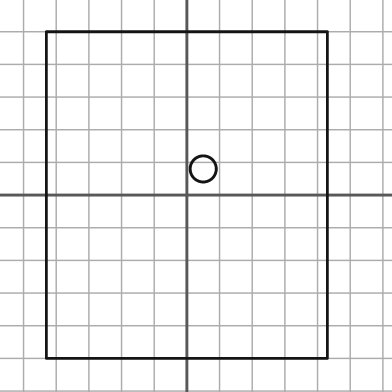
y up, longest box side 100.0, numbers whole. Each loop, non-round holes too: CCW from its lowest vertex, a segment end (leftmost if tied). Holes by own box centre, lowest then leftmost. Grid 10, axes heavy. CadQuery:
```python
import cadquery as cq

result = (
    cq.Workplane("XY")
    .moveTo(-43.0, -50.0)
    .lineTo(43.0, -50.0)
    .lineTo(43.0, 50.0)
    .lineTo(-43.0, 50.0)
    .close()
    .moveTo(5.0, 8.0)
    .circle(4.0)
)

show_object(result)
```